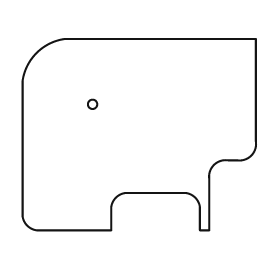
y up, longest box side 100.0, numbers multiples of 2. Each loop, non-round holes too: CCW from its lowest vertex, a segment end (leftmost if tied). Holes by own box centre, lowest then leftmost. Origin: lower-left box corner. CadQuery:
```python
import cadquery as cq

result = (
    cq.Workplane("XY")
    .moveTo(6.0, 0.0)
    .lineTo(38.0, 0.0)
    .lineTo(38.0, 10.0)
    .threePointArc((40.0, 14.0), (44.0, 16.0))
    .lineTo(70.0, 16.0)
    .threePointArc((74.0, 14.0), (76.0, 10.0))
    .lineTo(76.0, 0.0)
    .lineTo(80.0, 0.0)
    .lineTo(80.0, 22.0)
    .threePointArc((82.0, 28.0), (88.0, 30.0))
    .lineTo(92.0, 30.0)
    .threePointArc((98.0, 32.0), (100.0, 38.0))
    .lineTo(100.0, 82.0)
    .lineTo(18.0, 82.0)
    .threePointArc((6.0, 76.0), (0.0, 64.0))
    .lineTo(0.0, 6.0)
    .threePointArc((2.0, 2.0), (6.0, 0.0))
    .close()
    .moveTo(30.0, 54.0)
    .circle(2.0)
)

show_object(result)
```